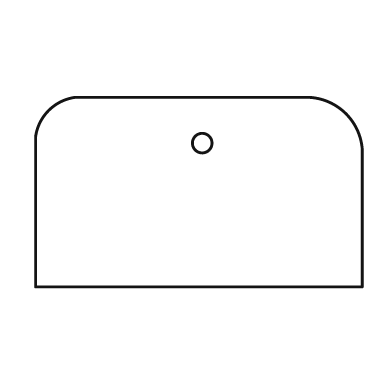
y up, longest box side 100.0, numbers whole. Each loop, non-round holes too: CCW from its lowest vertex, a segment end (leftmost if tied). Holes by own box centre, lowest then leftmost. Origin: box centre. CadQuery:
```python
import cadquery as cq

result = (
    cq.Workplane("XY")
    .moveTo(-50.0, -29.0)
    .lineTo(50.0, -29.0)
    .lineTo(50.0, 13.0)
    .threePointArc((45.0, 24.0), (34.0, 29.0))
    .lineTo(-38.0, 29.0)
    .threePointArc((-46.0, 25.0), (-50.0, 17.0))
    .close()
    .moveTo(1.0, 15.0)
    .circle(3.0)
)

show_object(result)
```